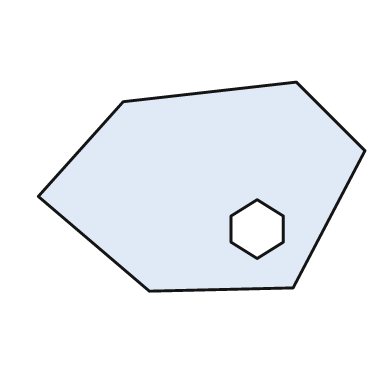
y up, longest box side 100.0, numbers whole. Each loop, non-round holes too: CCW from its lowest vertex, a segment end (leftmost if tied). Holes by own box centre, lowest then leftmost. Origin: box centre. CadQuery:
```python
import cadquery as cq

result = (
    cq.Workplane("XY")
    .moveTo(-16.0, -32.0)
    .lineTo(28.0, -31.0)
    .lineTo(50.0, 11.0)
    .lineTo(29.0, 32.0)
    .lineTo(-24.0, 26.0)
    .lineTo(-50.0, -3.0)
    .close()
    .moveTo(17.0, -22.0)
    .lineTo(25.0, -17.0)
    .lineTo(25.0, -9.0)
    .lineTo(17.0, -4.0)
    .lineTo(9.0, -9.0)
    .lineTo(9.0, -17.0)
    .close()
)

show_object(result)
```